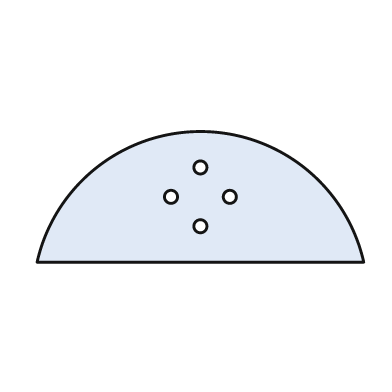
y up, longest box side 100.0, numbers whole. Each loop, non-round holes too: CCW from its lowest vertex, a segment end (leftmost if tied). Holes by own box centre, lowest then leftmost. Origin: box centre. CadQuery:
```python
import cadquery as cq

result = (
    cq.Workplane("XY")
    .moveTo(-50.0, -20.0)
    .lineTo(50.0, -20.0)
    .threePointArc((0.0, 20.0), (-50.0, -20.0))
    .close()
    .moveTo(0.0, -9.0)
    .circle(2.0)
    .moveTo(-9.0, 0.0)
    .circle(2.0)
    .moveTo(9.0, 0.0)
    .circle(2.0)
    .moveTo(0.0, 9.0)
    .circle(2.0)
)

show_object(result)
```